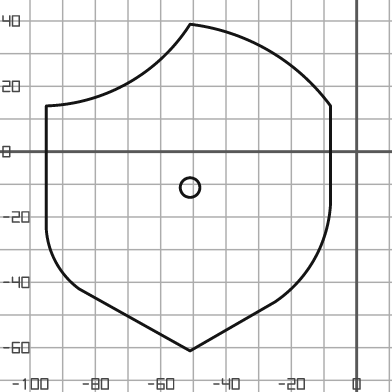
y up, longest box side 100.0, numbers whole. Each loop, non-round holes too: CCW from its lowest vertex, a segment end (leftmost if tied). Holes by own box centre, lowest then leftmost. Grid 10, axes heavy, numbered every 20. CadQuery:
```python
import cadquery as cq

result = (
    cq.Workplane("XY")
    .moveTo(-51.0, -61.0)
    .lineTo(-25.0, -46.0)
    .threePointArc((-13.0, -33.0), (-8.0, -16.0))
    .lineTo(-8.0, 14.0)
    .threePointArc((-27.0, 31.0), (-51.0, 39.0))
    .threePointArc((-70.0, 21.0), (-95.0, 14.0))
    .lineTo(-95.0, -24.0)
    .threePointArc((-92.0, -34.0), (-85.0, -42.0))
    .close()
    .moveTo(-51.0, -11.0)
    .circle(3.0)
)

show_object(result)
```